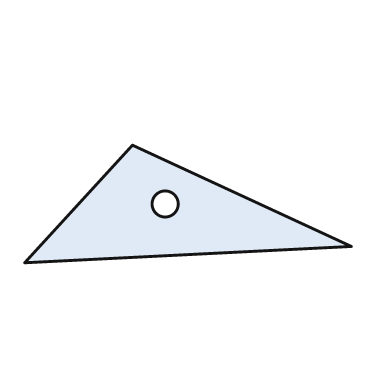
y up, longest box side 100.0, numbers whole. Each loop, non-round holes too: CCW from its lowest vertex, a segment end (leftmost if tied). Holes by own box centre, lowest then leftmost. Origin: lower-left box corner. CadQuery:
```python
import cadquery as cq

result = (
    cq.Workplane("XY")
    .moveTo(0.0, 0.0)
    .lineTo(100.0, 5.0)
    .lineTo(33.0, 36.0)
    .close()
    .moveTo(43.0, 18.0)
    .circle(4.0)
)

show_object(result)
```